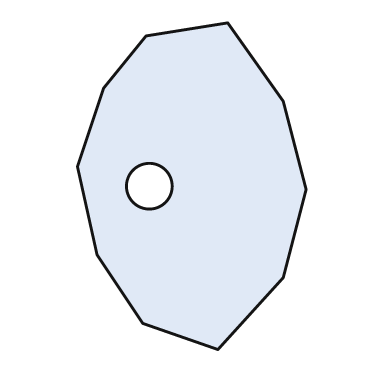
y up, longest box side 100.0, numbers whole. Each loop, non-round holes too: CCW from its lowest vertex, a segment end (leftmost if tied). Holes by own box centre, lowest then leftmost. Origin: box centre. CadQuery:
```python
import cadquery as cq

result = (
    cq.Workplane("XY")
    .moveTo(8.0, -50.0)
    .lineTo(28.0, -28.0)
    .lineTo(35.0, -1.0)
    .lineTo(28.0, 26.0)
    .lineTo(11.0, 50.0)
    .lineTo(-14.0, 46.0)
    .lineTo(-27.0, 30.0)
    .lineTo(-35.0, 6.0)
    .lineTo(-29.0, -21.0)
    .lineTo(-15.0, -42.0)
    .close()
    .moveTo(-13.0, 0.0)
    .circle(7.0)
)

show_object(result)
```